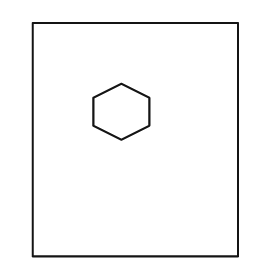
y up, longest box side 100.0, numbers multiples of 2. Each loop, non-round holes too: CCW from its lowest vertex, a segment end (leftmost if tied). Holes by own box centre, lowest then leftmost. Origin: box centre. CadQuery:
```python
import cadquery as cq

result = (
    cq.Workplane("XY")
    .moveTo(-44.0, -50.0)
    .lineTo(44.0, -50.0)
    .lineTo(44.0, 50.0)
    .lineTo(-44.0, 50.0)
    .close()
    .moveTo(-6.0, 0.0)
    .lineTo(6.0, 6.0)
    .lineTo(6.0, 18.0)
    .lineTo(-6.0, 24.0)
    .lineTo(-18.0, 18.0)
    .lineTo(-18.0, 6.0)
    .close()
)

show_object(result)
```